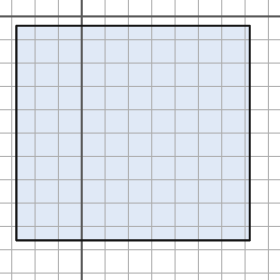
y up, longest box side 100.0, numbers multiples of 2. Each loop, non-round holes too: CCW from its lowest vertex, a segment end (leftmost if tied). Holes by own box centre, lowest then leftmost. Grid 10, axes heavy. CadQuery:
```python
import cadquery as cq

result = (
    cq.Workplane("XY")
    .moveTo(-28.0, -96.0)
    .lineTo(72.0, -96.0)
    .lineTo(72.0, -4.0)
    .lineTo(-28.0, -4.0)
    .close()
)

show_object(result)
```